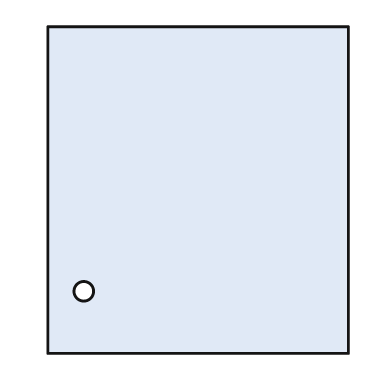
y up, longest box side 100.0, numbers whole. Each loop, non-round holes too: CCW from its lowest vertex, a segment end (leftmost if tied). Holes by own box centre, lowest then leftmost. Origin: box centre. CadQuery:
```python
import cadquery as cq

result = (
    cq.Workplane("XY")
    .moveTo(-46.0, -50.0)
    .lineTo(46.0, -50.0)
    .lineTo(46.0, 50.0)
    .lineTo(-46.0, 50.0)
    .close()
    .moveTo(-35.0, -31.0)
    .circle(3.0)
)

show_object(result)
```